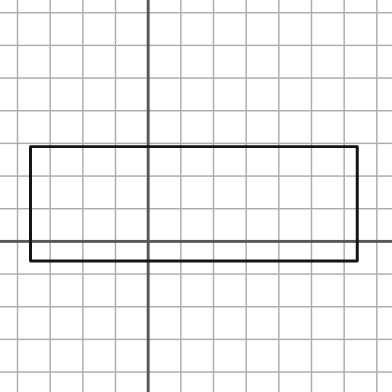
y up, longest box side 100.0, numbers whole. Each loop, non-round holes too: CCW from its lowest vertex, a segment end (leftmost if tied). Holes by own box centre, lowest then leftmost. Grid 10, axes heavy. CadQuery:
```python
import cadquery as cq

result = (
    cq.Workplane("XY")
    .moveTo(-36.0, -6.0)
    .lineTo(64.0, -6.0)
    .lineTo(64.0, 29.0)
    .lineTo(-36.0, 29.0)
    .close()
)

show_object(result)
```